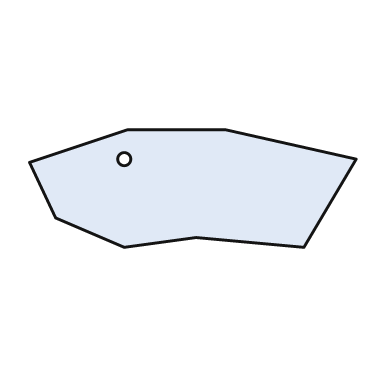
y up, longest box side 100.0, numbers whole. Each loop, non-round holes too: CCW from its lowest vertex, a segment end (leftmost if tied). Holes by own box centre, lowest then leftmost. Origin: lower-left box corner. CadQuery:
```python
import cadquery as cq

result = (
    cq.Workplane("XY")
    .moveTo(29.0, 0.0)
    .lineTo(51.0, 3.0)
    .lineTo(84.0, 0.0)
    .lineTo(100.0, 27.0)
    .lineTo(60.0, 36.0)
    .lineTo(30.0, 36.0)
    .lineTo(0.0, 26.0)
    .lineTo(8.0, 9.0)
    .close()
    .moveTo(29.0, 27.0)
    .circle(2.0)
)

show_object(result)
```